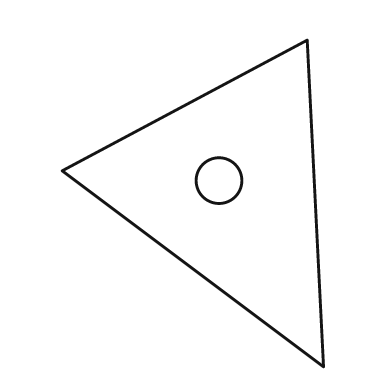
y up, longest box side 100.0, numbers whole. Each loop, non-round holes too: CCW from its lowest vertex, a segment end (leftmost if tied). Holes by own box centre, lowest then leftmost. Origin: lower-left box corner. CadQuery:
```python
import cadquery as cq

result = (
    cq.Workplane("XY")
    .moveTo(80.0, 0.0)
    .lineTo(75.0, 100.0)
    .lineTo(0.0, 60.0)
    .close()
    .moveTo(48.0, 57.0)
    .circle(7.0)
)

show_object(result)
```